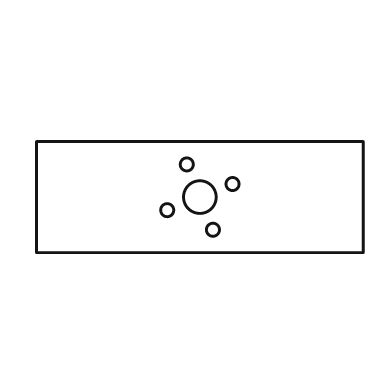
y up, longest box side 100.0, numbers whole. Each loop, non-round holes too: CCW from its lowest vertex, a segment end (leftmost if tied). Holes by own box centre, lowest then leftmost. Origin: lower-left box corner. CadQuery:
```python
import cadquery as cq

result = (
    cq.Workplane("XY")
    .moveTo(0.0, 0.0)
    .lineTo(100.0, 0.0)
    .lineTo(100.0, 34.0)
    .lineTo(0.0, 34.0)
    .close()
    .moveTo(54.0, 7.0)
    .circle(2.0)
    .moveTo(40.0, 13.0)
    .circle(2.0)
    .moveTo(50.0, 17.0)
    .circle(5.0)
    .moveTo(60.0, 21.0)
    .circle(2.0)
    .moveTo(46.0, 27.0)
    .circle(2.0)
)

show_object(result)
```